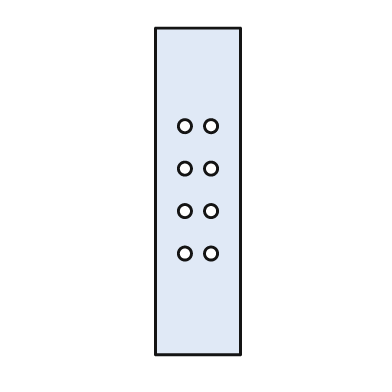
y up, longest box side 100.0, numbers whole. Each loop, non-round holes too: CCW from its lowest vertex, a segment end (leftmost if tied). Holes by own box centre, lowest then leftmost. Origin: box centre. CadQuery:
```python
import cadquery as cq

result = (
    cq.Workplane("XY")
    .moveTo(-13.0, -50.0)
    .lineTo(13.0, -50.0)
    .lineTo(13.0, 50.0)
    .lineTo(-13.0, 50.0)
    .close()
    .moveTo(-4.0, -19.0)
    .circle(2.0)
    .moveTo(4.0, -19.0)
    .circle(2.0)
    .moveTo(-4.0, -6.0)
    .circle(2.0)
    .moveTo(4.0, -6.0)
    .circle(2.0)
    .moveTo(-4.0, 7.0)
    .circle(2.0)
    .moveTo(4.0, 7.0)
    .circle(2.0)
    .moveTo(-4.0, 20.0)
    .circle(2.0)
    .moveTo(4.0, 20.0)
    .circle(2.0)
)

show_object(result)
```